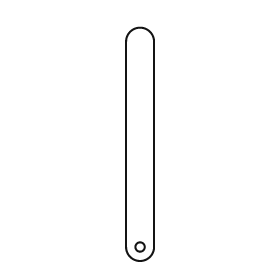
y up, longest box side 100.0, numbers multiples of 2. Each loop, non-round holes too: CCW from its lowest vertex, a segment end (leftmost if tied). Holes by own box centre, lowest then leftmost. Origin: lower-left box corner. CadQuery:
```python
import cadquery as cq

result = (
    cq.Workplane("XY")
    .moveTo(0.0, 6.0)
    .threePointArc((6.0, 0.0), (12.0, 6.0))
    .lineTo(12.0, 94.0)
    .threePointArc((6.0, 100.0), (0.0, 94.0))
    .close()
    .moveTo(6.0, 6.0)
    .circle(2.0)
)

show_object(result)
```